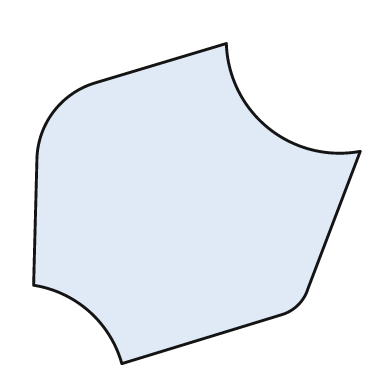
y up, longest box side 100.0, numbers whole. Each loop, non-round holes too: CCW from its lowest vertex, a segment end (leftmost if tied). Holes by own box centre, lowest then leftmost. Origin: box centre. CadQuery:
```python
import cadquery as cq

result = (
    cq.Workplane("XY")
    .moveTo(-23.0, -49.0)
    .lineTo(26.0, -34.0)
    .threePointArc((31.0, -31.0), (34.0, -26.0))
    .lineTo(50.0, 16.0)
    .threePointArc((22.0, 23.0), (9.0, 49.0))
    .lineTo(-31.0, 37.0)
    .threePointArc((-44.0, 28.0), (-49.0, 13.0))
    .lineTo(-50.0, -25.0)
    .threePointArc((-33.0, -33.0), (-23.0, -49.0))
    .close()
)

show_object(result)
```